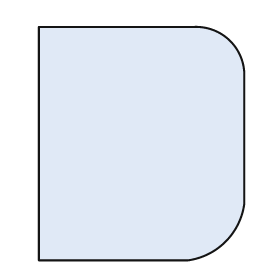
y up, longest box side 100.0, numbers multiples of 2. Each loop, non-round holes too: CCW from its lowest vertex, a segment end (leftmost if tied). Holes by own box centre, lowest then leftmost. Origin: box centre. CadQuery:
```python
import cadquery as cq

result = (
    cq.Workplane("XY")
    .moveTo(-44.0, -50.0)
    .lineTo(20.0, -50.0)
    .threePointArc((36.0, -42.0), (44.0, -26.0))
    .lineTo(44.0, 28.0)
    .threePointArc((38.0, 44.0), (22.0, 50.0))
    .lineTo(-44.0, 50.0)
    .close()
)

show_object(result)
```